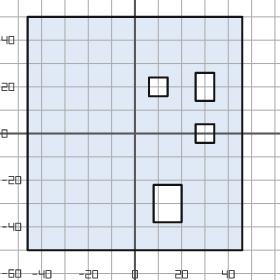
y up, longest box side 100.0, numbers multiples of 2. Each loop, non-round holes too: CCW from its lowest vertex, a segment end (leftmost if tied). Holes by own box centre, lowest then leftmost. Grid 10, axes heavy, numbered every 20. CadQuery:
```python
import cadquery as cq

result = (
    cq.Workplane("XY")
    .moveTo(-46.0, -50.0)
    .lineTo(46.0, -50.0)
    .lineTo(46.0, 50.0)
    .lineTo(-46.0, 50.0)
    .close()
    .moveTo(8.0, -38.0)
    .lineTo(20.0, -38.0)
    .lineTo(20.0, -22.0)
    .lineTo(8.0, -22.0)
    .close()
    .moveTo(26.0, -4.0)
    .lineTo(34.0, -4.0)
    .lineTo(34.0, 4.0)
    .lineTo(26.0, 4.0)
    .close()
    .moveTo(6.0, 16.0)
    .lineTo(14.0, 16.0)
    .lineTo(14.0, 24.0)
    .lineTo(6.0, 24.0)
    .close()
    .moveTo(26.0, 14.0)
    .lineTo(34.0, 14.0)
    .lineTo(34.0, 26.0)
    .lineTo(26.0, 26.0)
    .close()
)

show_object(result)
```